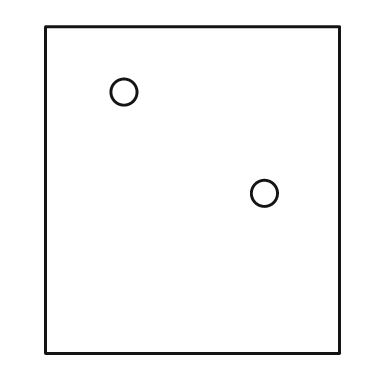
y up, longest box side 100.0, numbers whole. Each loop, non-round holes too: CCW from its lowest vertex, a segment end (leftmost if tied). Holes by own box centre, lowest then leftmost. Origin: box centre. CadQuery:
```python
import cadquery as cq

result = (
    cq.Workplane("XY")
    .moveTo(-45.0, -50.0)
    .lineTo(45.0, -50.0)
    .lineTo(45.0, 50.0)
    .lineTo(-45.0, 50.0)
    .close()
    .moveTo(22.0, -1.0)
    .circle(4.0)
    .moveTo(-21.0, 30.0)
    .circle(4.0)
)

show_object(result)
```